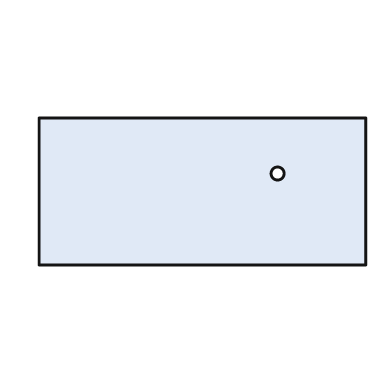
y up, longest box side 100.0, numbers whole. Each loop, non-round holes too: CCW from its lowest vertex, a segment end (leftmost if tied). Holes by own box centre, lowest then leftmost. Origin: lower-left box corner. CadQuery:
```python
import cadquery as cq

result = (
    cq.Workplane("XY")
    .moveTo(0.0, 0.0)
    .lineTo(100.0, 0.0)
    .lineTo(100.0, 45.0)
    .lineTo(0.0, 45.0)
    .close()
    .moveTo(73.0, 28.0)
    .circle(2.0)
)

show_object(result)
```